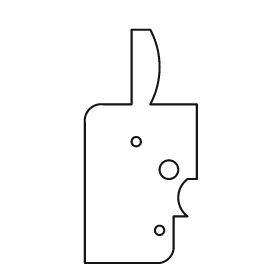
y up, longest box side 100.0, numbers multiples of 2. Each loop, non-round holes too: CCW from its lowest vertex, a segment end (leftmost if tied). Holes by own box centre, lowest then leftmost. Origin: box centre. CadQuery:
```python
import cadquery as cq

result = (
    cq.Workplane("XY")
    .moveTo(-24.0, -50.0)
    .lineTo(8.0, -50.0)
    .threePointArc((12.0, -48.0), (14.0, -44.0))
    .lineTo(14.0, -30.0)
    .lineTo(20.0, -30.0)
    .threePointArc((16.0, -22.0), (20.0, -14.0))
    .lineTo(24.0, -14.0)
    .lineTo(24.0, 18.0)
    .lineTo(4.0, 18.0)
    .threePointArc((8.0, 34.0), (4.0, 50.0))
    .lineTo(-4.0, 50.0)
    .lineTo(-4.0, 18.0)
    .lineTo(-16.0, 18.0)
    .threePointArc((-22.0, 16.0), (-24.0, 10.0))
    .close()
    .moveTo(8.0, -36.0)
    .circle(2.0)
    .moveTo(12.0, -10.0)
    .circle(4.0)
    .moveTo(-2.0, 2.0)
    .circle(2.0)
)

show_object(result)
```